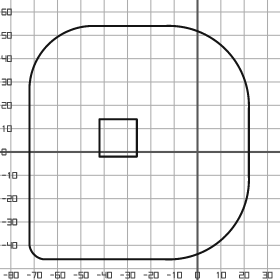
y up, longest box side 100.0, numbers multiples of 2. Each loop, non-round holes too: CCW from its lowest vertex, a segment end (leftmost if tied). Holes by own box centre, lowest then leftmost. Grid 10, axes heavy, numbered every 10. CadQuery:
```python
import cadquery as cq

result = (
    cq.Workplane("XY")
    .moveTo(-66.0, -46.0)
    .lineTo(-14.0, -46.0)
    .threePointArc((12.0, -36.0), (22.0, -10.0))
    .lineTo(22.0, 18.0)
    .threePointArc((12.0, 44.0), (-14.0, 54.0))
    .lineTo(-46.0, 54.0)
    .threePointArc((-64.0, 46.0), (-72.0, 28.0))
    .lineTo(-72.0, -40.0)
    .threePointArc((-70.0, -44.0), (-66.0, -46.0))
    .close()
    .moveTo(-42.0, -2.0)
    .lineTo(-26.0, -2.0)
    .lineTo(-26.0, 14.0)
    .lineTo(-42.0, 14.0)
    .close()
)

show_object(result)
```